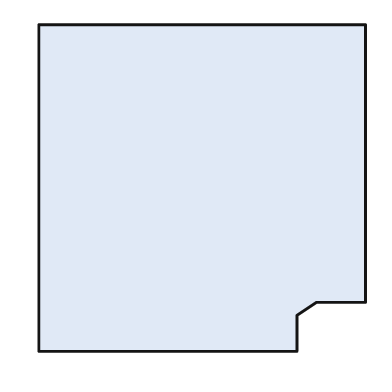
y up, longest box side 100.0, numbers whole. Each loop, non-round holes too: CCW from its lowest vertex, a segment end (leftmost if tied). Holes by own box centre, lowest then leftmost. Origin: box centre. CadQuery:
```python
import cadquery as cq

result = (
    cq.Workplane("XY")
    .moveTo(-50.0, -50.0)
    .lineTo(29.0, -50.0)
    .lineTo(29.0, -39.0)
    .lineTo(35.0, -35.0)
    .lineTo(50.0, -35.0)
    .lineTo(50.0, 50.0)
    .lineTo(-50.0, 50.0)
    .close()
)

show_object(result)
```